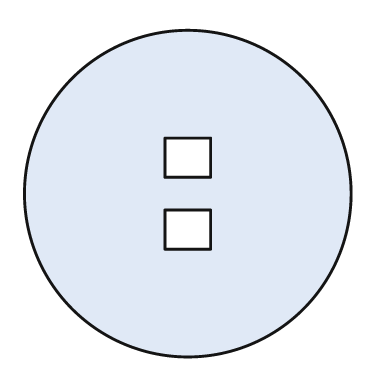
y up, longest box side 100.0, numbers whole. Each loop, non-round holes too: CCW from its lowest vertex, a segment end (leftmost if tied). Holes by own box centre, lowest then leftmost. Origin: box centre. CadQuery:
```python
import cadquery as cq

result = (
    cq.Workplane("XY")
    .moveTo(0.0, 0.0)
    .circle(50.0)
    .moveTo(-7.0, -17.0)
    .lineTo(7.0, -17.0)
    .lineTo(7.0, -5.0)
    .lineTo(-7.0, -5.0)
    .close()
    .moveTo(-7.0, 5.0)
    .lineTo(7.0, 5.0)
    .lineTo(7.0, 17.0)
    .lineTo(-7.0, 17.0)
    .close()
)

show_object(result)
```